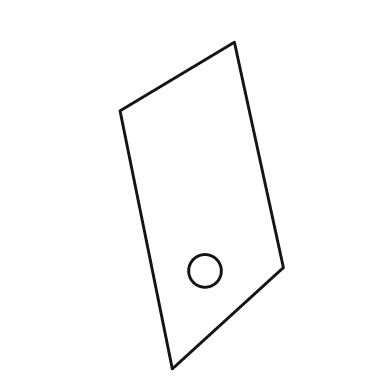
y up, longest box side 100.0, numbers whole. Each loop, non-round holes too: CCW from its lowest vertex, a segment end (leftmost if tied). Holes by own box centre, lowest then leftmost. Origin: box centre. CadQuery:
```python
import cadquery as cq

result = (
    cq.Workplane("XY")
    .moveTo(-9.0, -50.0)
    .lineTo(25.0, -19.0)
    .lineTo(10.0, 50.0)
    .lineTo(-25.0, 29.0)
    .close()
    .moveTo(1.0, -20.0)
    .circle(5.0)
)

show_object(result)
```